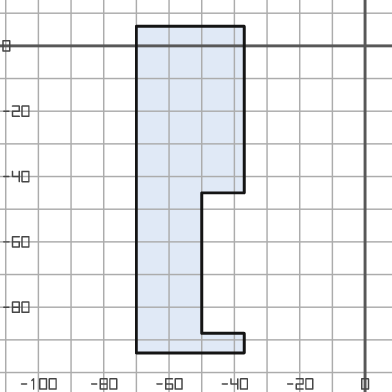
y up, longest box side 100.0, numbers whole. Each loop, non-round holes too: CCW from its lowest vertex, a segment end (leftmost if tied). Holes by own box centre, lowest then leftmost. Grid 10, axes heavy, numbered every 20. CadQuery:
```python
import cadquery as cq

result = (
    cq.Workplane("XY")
    .moveTo(-70.0, -94.0)
    .lineTo(-37.0, -94.0)
    .lineTo(-37.0, -88.0)
    .lineTo(-50.0, -88.0)
    .lineTo(-50.0, -45.0)
    .lineTo(-37.0, -45.0)
    .lineTo(-37.0, 6.0)
    .lineTo(-70.0, 6.0)
    .close()
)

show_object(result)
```